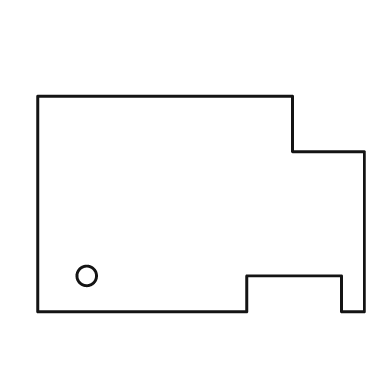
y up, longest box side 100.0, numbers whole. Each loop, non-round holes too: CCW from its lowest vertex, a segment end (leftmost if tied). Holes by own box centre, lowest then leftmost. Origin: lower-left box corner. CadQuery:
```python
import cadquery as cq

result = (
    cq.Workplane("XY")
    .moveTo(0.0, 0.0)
    .lineTo(64.0, 0.0)
    .lineTo(64.0, 11.0)
    .lineTo(93.0, 11.0)
    .lineTo(93.0, 0.0)
    .lineTo(100.0, 0.0)
    .lineTo(100.0, 49.0)
    .lineTo(78.0, 49.0)
    .lineTo(78.0, 66.0)
    .lineTo(0.0, 66.0)
    .close()
    .moveTo(15.0, 11.0)
    .circle(3.0)
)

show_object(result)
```